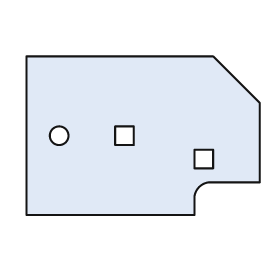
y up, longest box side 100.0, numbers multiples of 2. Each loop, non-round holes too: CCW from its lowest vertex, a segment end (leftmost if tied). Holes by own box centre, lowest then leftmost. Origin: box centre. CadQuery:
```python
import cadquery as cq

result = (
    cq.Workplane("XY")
    .moveTo(-50.0, -34.0)
    .lineTo(22.0, -34.0)
    .lineTo(22.0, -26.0)
    .threePointArc((24.0, -22.0), (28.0, -20.0))
    .lineTo(50.0, -20.0)
    .lineTo(50.0, 14.0)
    .lineTo(30.0, 34.0)
    .lineTo(-50.0, 34.0)
    .close()
    .moveTo(22.0, -14.0)
    .lineTo(30.0, -14.0)
    .lineTo(30.0, -6.0)
    .lineTo(22.0, -6.0)
    .close()
    .moveTo(-36.0, 0.0)
    .circle(4.0)
    .moveTo(-12.0, -4.0)
    .lineTo(-4.0, -4.0)
    .lineTo(-4.0, 4.0)
    .lineTo(-12.0, 4.0)
    .close()
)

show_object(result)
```